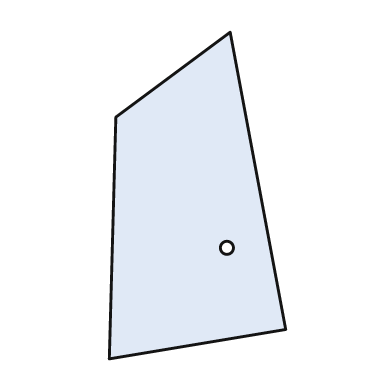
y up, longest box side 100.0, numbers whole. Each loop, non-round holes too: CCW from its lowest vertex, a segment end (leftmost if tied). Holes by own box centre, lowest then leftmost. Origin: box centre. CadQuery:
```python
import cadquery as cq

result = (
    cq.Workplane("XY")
    .moveTo(-27.0, -50.0)
    .lineTo(27.0, -41.0)
    .lineTo(10.0, 50.0)
    .lineTo(-25.0, 24.0)
    .close()
    .moveTo(9.0, -16.0)
    .circle(2.0)
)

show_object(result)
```